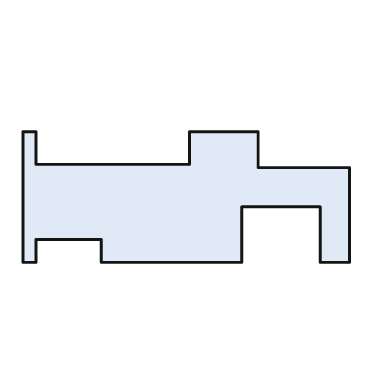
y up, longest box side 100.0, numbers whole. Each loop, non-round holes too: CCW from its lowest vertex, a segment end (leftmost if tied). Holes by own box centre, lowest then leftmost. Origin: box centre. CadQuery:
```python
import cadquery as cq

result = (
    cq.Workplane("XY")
    .moveTo(-50.0, -20.0)
    .lineTo(-46.0, -20.0)
    .lineTo(-46.0, -13.0)
    .lineTo(-26.0, -13.0)
    .lineTo(-26.0, -20.0)
    .lineTo(17.0, -20.0)
    .lineTo(17.0, -3.0)
    .lineTo(41.0, -3.0)
    .lineTo(41.0, -20.0)
    .lineTo(50.0, -20.0)
    .lineTo(50.0, 9.0)
    .lineTo(22.0, 9.0)
    .lineTo(22.0, 20.0)
    .lineTo(1.0, 20.0)
    .lineTo(1.0, 10.0)
    .lineTo(-46.0, 10.0)
    .lineTo(-46.0, 20.0)
    .lineTo(-50.0, 20.0)
    .close()
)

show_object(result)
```